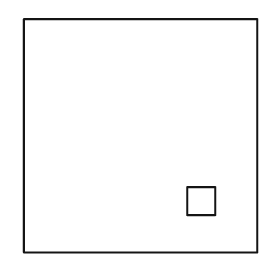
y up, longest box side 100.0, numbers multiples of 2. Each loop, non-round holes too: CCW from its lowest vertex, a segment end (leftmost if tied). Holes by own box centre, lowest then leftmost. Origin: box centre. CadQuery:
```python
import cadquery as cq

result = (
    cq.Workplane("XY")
    .moveTo(-50.0, -50.0)
    .lineTo(50.0, -50.0)
    .lineTo(50.0, 50.0)
    .lineTo(-50.0, 50.0)
    .close()
    .moveTo(20.0, -34.0)
    .lineTo(32.0, -34.0)
    .lineTo(32.0, -22.0)
    .lineTo(20.0, -22.0)
    .close()
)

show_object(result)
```